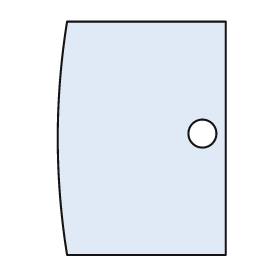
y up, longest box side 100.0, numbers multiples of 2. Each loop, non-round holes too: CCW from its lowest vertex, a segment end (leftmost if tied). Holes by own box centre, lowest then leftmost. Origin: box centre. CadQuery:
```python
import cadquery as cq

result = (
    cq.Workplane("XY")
    .moveTo(-32.0, -50.0)
    .lineTo(36.0, -50.0)
    .lineTo(36.0, 50.0)
    .lineTo(-32.0, 50.0)
    .threePointArc((-36.0, 0.0), (-32.0, -50.0))
    .close()
    .moveTo(26.0, 2.0)
    .circle(6.0)
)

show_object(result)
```